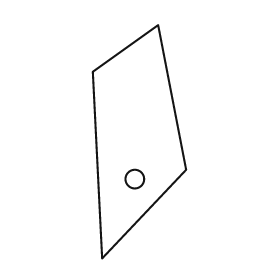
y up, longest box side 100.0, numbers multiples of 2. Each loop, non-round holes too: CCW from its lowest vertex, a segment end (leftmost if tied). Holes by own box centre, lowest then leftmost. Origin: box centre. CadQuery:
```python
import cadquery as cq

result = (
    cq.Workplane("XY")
    .moveTo(-16.0, -50.0)
    .lineTo(20.0, -12.0)
    .lineTo(8.0, 50.0)
    .lineTo(-20.0, 30.0)
    .close()
    .moveTo(-2.0, -16.0)
    .circle(4.0)
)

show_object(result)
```